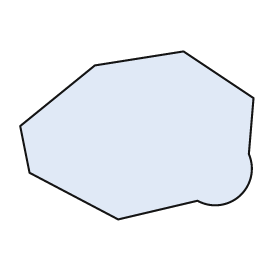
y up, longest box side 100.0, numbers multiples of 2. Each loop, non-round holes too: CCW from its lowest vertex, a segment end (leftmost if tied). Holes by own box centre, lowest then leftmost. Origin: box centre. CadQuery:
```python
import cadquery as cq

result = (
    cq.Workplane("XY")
    .moveTo(-8.0, -36.0)
    .lineTo(26.0, -28.0)
    .threePointArc((44.0, -26.0), (48.0, -8.0))
    .lineTo(50.0, 16.0)
    .lineTo(20.0, 36.0)
    .lineTo(-18.0, 30.0)
    .lineTo(-50.0, 4.0)
    .lineTo(-46.0, -16.0)
    .close()
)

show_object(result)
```